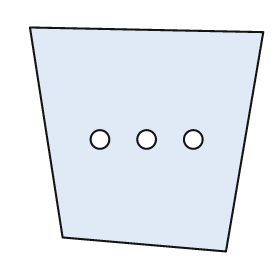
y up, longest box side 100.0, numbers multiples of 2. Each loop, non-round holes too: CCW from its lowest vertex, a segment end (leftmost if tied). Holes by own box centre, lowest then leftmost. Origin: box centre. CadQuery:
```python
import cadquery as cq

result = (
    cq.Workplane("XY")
    .moveTo(34.0, -48.0)
    .lineTo(50.0, 46.0)
    .lineTo(-50.0, 48.0)
    .lineTo(-36.0, -42.0)
    .close()
    .moveTo(-20.0, 0.0)
    .circle(4.0)
    .moveTo(0.0, 0.0)
    .circle(4.0)
    .moveTo(20.0, 0.0)
    .circle(4.0)
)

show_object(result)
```